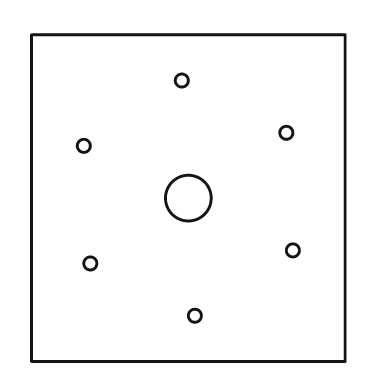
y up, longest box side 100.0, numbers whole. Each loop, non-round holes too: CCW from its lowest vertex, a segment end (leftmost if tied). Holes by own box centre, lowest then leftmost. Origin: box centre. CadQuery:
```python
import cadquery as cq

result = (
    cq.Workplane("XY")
    .moveTo(-48.0, -50.0)
    .lineTo(48.0, -50.0)
    .lineTo(48.0, 50.0)
    .lineTo(-48.0, 50.0)
    .close()
    .moveTo(2.0, -36.0)
    .circle(2.0)
    .moveTo(-30.0, -20.0)
    .circle(2.0)
    .moveTo(32.0, -16.0)
    .circle(2.0)
    .moveTo(0.0, 0.0)
    .circle(7.0)
    .moveTo(-32.0, 16.0)
    .circle(2.0)
    .moveTo(30.0, 20.0)
    .circle(2.0)
    .moveTo(-2.0, 36.0)
    .circle(2.0)
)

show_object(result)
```